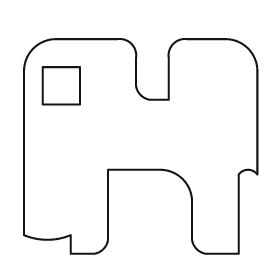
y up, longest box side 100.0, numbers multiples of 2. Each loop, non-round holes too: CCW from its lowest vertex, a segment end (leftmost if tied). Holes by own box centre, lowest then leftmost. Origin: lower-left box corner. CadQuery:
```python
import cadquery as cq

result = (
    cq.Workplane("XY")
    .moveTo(20.0, 0.0)
    .lineTo(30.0, 0.0)
    .threePointArc((34.0, 2.0), (36.0, 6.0))
    .lineTo(36.0, 36.0)
    .lineTo(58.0, 36.0)
    .threePointArc((68.0, 32.0), (72.0, 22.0))
    .lineTo(72.0, 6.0)
    .threePointArc((74.0, 2.0), (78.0, 0.0))
    .lineTo(92.0, 0.0)
    .lineTo(92.0, 34.0)
    .threePointArc((96.0, 36.0), (100.0, 34.0))
    .lineTo(100.0, 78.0)
    .threePointArc((96.0, 88.0), (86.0, 92.0))
    .lineTo(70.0, 92.0)
    .threePointArc((64.0, 90.0), (62.0, 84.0))
    .lineTo(62.0, 66.0)
    .lineTo(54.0, 66.0)
    .threePointArc((50.0, 68.0), (48.0, 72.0))
    .lineTo(48.0, 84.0)
    .threePointArc((46.0, 90.0), (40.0, 92.0))
    .lineTo(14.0, 92.0)
    .threePointArc((4.0, 88.0), (0.0, 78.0))
    .lineTo(0.0, 8.0)
    .threePointArc((10.0, 6.0), (20.0, 8.0))
    .close()
    .moveTo(8.0, 64.0)
    .lineTo(24.0, 64.0)
    .lineTo(24.0, 80.0)
    .lineTo(8.0, 80.0)
    .close()
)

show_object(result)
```